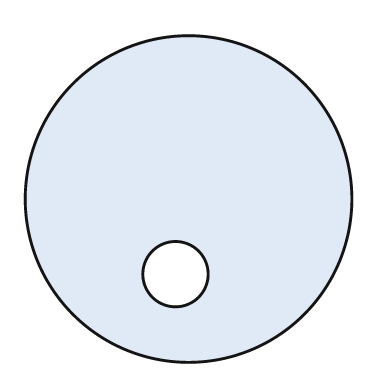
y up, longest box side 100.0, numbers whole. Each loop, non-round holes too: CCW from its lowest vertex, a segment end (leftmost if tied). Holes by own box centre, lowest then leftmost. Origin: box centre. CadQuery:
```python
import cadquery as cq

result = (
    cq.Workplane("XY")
    .moveTo(0.0, 0.0)
    .circle(50.0)
    .moveTo(-4.0, -23.0)
    .circle(10.0)
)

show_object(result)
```